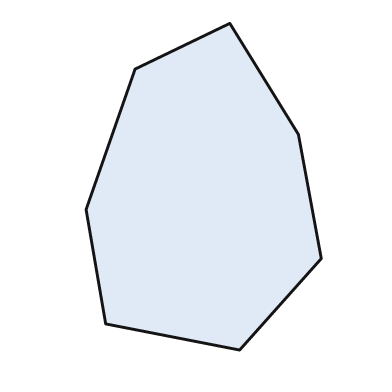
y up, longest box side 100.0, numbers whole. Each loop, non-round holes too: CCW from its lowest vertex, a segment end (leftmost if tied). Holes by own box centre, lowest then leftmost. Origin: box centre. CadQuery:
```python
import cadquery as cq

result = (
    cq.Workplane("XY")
    .moveTo(11.0, -50.0)
    .lineTo(36.0, -22.0)
    .lineTo(29.0, 16.0)
    .lineTo(8.0, 50.0)
    .lineTo(-21.0, 36.0)
    .lineTo(-36.0, -7.0)
    .lineTo(-30.0, -42.0)
    .close()
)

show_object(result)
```